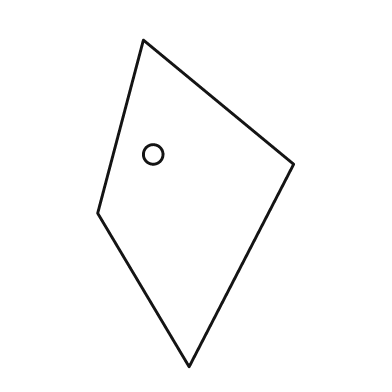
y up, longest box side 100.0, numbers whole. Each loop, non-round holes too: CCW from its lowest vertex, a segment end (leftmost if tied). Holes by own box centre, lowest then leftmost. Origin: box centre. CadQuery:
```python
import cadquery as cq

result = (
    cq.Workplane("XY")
    .moveTo(-2.0, -50.0)
    .lineTo(30.0, 12.0)
    .lineTo(-16.0, 50.0)
    .lineTo(-30.0, -3.0)
    .close()
    .moveTo(-13.0, 15.0)
    .circle(3.0)
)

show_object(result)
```